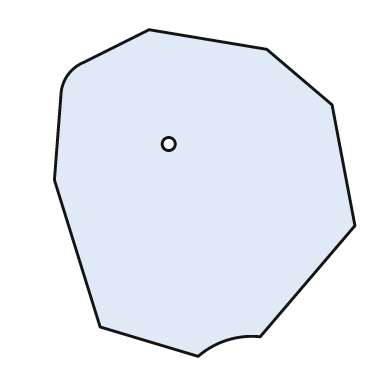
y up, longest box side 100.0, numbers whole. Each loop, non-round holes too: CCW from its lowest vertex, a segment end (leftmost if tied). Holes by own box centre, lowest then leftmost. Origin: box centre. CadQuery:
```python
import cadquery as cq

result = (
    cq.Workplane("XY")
    .moveTo(-2.0, -50.0)
    .threePointArc((7.0, -45.0), (17.0, -44.0))
    .lineTo(46.0, -10.0)
    .lineTo(39.0, 27.0)
    .lineTo(19.0, 44.0)
    .lineTo(-17.0, 50.0)
    .lineTo(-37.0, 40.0)
    .threePointArc((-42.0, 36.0), (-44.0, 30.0))
    .lineTo(-46.0, 4.0)
    .lineTo(-32.0, -41.0)
    .close()
    .moveTo(-11.0, 15.0)
    .circle(2.0)
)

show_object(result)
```